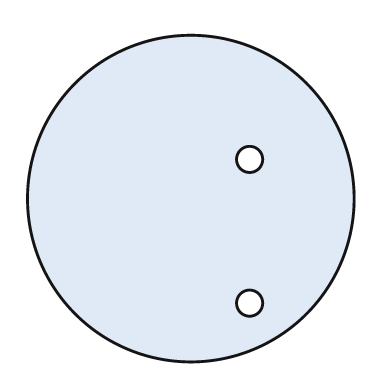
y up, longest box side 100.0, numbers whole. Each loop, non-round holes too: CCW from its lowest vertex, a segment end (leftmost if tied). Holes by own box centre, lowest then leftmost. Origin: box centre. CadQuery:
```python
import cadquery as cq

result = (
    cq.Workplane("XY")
    .moveTo(0.0, 0.0)
    .circle(50.0)
    .moveTo(18.0, -32.0)
    .circle(4.0)
    .moveTo(18.0, 12.0)
    .circle(4.0)
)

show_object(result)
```